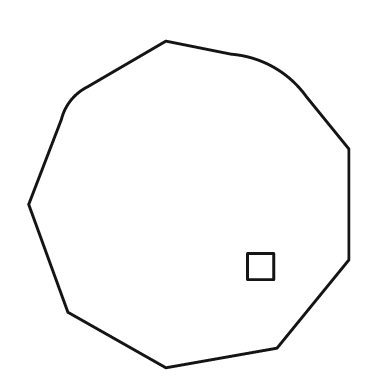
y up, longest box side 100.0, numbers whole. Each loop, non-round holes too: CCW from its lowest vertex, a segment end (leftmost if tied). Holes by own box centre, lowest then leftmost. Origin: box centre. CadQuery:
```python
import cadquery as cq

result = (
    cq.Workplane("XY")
    .moveTo(-7.0, -50.0)
    .lineTo(27.0, -44.0)
    .lineTo(49.0, -17.0)
    .lineTo(49.0, 17.0)
    .lineTo(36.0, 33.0)
    .threePointArc((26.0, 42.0), (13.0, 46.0))
    .lineTo(-7.0, 50.0)
    .lineTo(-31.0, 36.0)
    .threePointArc((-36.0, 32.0), (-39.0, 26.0))
    .lineTo(-49.0, 0.0)
    .lineTo(-37.0, -33.0)
    .close()
    .moveTo(18.0, -23.0)
    .lineTo(26.0, -23.0)
    .lineTo(26.0, -15.0)
    .lineTo(18.0, -15.0)
    .close()
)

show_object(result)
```